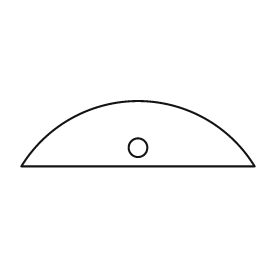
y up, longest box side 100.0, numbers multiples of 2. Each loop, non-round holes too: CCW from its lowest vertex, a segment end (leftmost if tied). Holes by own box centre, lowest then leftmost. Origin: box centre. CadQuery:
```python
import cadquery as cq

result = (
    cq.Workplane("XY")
    .moveTo(-50.0, -14.0)
    .lineTo(50.0, -14.0)
    .threePointArc((0.0, 14.0), (-50.0, -14.0))
    .close()
    .moveTo(0.0, -6.0)
    .circle(4.0)
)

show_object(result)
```